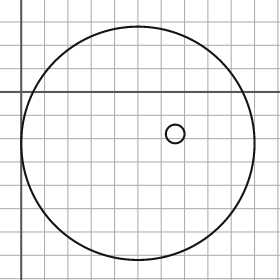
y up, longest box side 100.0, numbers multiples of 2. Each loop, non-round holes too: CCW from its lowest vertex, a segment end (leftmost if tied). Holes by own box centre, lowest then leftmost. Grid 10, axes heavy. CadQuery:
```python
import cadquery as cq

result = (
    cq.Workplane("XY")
    .moveTo(50.0, -22.0)
    .circle(50.0)
    .moveTo(66.0, -18.0)
    .circle(4.0)
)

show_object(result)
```